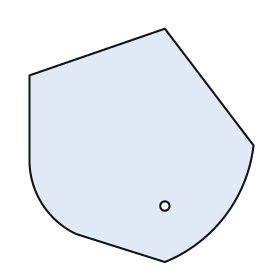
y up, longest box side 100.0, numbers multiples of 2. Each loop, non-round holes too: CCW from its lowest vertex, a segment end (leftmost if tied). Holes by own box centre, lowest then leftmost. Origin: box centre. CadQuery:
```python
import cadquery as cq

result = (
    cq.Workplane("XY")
    .moveTo(10.0, -50.0)
    .threePointArc((36.0, -30.0), (48.0, 0.0))
    .lineTo(10.0, 50.0)
    .lineTo(-48.0, 30.0)
    .lineTo(-48.0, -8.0)
    .threePointArc((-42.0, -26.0), (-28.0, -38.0))
    .close()
    .moveTo(10.0, -26.0)
    .circle(2.0)
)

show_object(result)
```